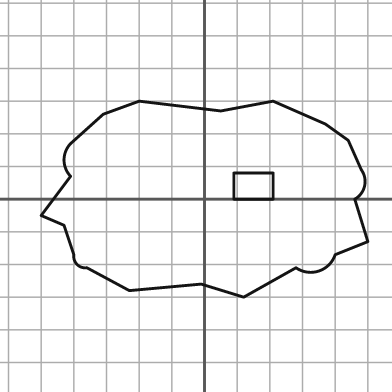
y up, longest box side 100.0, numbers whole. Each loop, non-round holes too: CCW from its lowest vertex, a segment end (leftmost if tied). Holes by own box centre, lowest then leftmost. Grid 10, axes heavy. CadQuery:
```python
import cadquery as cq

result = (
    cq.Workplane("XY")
    .moveTo(12.0, -30.0)
    .lineTo(28.0, -21.0)
    .threePointArc((35.0, -22.0), (40.0, -17.0))
    .lineTo(50.0, -13.0)
    .lineTo(46.0, 0.0)
    .threePointArc((49.0, 4.0), (48.0, 9.0))
    .lineTo(44.0, 18.0)
    .lineTo(37.0, 23.0)
    .lineTo(21.0, 30.0)
    .lineTo(5.0, 27.0)
    .lineTo(-20.0, 30.0)
    .lineTo(-31.0, 26.0)
    .lineTo(-41.0, 17.0)
    .threePointArc((-43.0, 12.0), (-41.0, 7.0))
    .lineTo(-50.0, -5.0)
    .lineTo(-43.0, -8.0)
    .lineTo(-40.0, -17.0)
    .threePointArc((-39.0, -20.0), (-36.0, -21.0))
    .lineTo(-23.0, -28.0)
    .lineTo(-1.0, -26.0)
    .close()
    .moveTo(9.0, 0.0)
    .lineTo(21.0, 0.0)
    .lineTo(21.0, 8.0)
    .lineTo(9.0, 8.0)
    .close()
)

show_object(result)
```